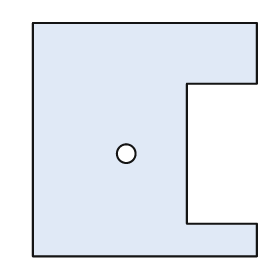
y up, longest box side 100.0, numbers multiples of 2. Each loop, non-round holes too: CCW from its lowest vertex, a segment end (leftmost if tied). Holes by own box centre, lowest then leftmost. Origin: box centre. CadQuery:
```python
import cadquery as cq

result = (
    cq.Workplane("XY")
    .moveTo(-48.0, -50.0)
    .lineTo(48.0, -50.0)
    .lineTo(48.0, -36.0)
    .lineTo(18.0, -36.0)
    .lineTo(18.0, 24.0)
    .lineTo(48.0, 24.0)
    .lineTo(48.0, 50.0)
    .lineTo(-48.0, 50.0)
    .close()
    .moveTo(-8.0, -6.0)
    .circle(4.0)
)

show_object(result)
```